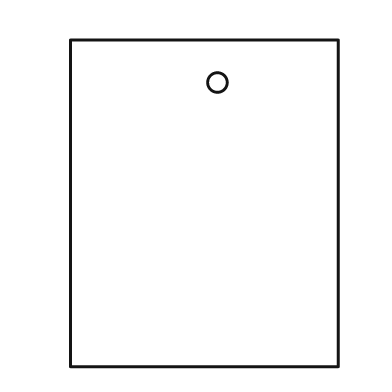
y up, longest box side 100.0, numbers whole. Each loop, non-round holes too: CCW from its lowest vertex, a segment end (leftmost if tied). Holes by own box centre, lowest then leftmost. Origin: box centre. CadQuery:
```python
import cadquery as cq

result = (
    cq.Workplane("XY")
    .moveTo(-41.0, -50.0)
    .lineTo(41.0, -50.0)
    .lineTo(41.0, 50.0)
    .lineTo(-41.0, 50.0)
    .close()
    .moveTo(4.0, 37.0)
    .circle(3.0)
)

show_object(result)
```